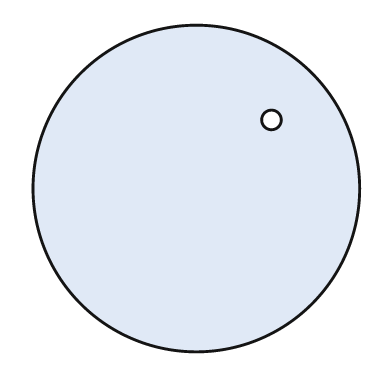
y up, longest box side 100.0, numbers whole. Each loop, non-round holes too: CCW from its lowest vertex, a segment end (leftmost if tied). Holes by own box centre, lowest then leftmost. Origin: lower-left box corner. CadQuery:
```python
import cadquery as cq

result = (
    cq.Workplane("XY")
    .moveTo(50.0, 50.0)
    .circle(50.0)
    .moveTo(73.0, 71.0)
    .circle(3.0)
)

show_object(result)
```